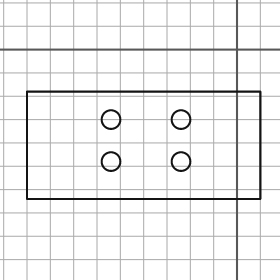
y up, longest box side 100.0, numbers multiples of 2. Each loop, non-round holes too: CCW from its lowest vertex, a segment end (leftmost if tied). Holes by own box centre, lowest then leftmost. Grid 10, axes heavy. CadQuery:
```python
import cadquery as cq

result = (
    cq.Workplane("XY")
    .moveTo(-90.0, -64.0)
    .lineTo(10.0, -64.0)
    .lineTo(10.0, -18.0)
    .lineTo(-90.0, -18.0)
    .close()
    .moveTo(-54.0, -48.0)
    .circle(4.0)
    .moveTo(-24.0, -48.0)
    .circle(4.0)
    .moveTo(-54.0, -30.0)
    .circle(4.0)
    .moveTo(-24.0, -30.0)
    .circle(4.0)
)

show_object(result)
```